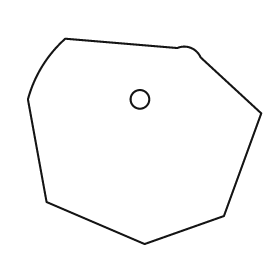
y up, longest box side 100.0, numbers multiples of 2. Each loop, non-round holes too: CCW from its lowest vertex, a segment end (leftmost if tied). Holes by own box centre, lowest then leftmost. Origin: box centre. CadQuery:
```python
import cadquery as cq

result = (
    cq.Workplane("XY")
    .moveTo(0.0, -44.0)
    .lineTo(34.0, -32.0)
    .lineTo(50.0, 12.0)
    .lineTo(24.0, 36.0)
    .threePointArc((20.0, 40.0), (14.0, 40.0))
    .lineTo(-34.0, 44.0)
    .threePointArc((-44.0, 32.0), (-50.0, 18.0))
    .lineTo(-42.0, -26.0)
    .close()
    .moveTo(-2.0, 18.0)
    .circle(4.0)
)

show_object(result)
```